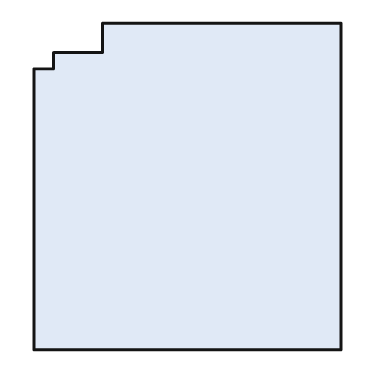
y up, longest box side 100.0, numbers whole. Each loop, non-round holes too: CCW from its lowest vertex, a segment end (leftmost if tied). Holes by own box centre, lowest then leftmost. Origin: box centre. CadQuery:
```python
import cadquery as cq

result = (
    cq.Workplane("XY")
    .moveTo(-47.0, -50.0)
    .lineTo(47.0, -50.0)
    .lineTo(47.0, 50.0)
    .lineTo(-26.0, 50.0)
    .lineTo(-26.0, 41.0)
    .lineTo(-41.0, 41.0)
    .lineTo(-41.0, 36.0)
    .lineTo(-47.0, 36.0)
    .close()
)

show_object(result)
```